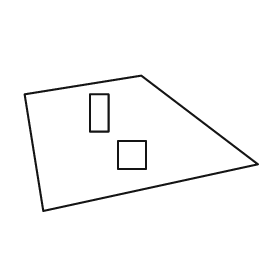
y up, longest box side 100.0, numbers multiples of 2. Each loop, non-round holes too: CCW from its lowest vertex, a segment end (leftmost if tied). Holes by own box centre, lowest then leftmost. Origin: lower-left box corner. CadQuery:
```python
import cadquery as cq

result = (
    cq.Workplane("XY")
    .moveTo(8.0, 0.0)
    .lineTo(100.0, 20.0)
    .lineTo(50.0, 58.0)
    .lineTo(0.0, 50.0)
    .close()
    .moveTo(40.0, 18.0)
    .lineTo(52.0, 18.0)
    .lineTo(52.0, 30.0)
    .lineTo(40.0, 30.0)
    .close()
    .moveTo(28.0, 34.0)
    .lineTo(36.0, 34.0)
    .lineTo(36.0, 50.0)
    .lineTo(28.0, 50.0)
    .close()
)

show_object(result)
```